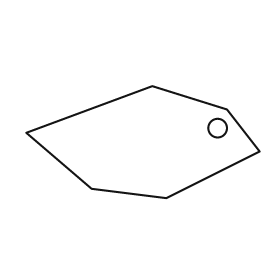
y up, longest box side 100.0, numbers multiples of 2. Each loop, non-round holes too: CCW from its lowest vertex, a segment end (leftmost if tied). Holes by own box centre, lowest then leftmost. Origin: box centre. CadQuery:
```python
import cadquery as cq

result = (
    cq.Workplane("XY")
    .moveTo(10.0, -24.0)
    .lineTo(50.0, -4.0)
    .lineTo(36.0, 14.0)
    .lineTo(4.0, 24.0)
    .lineTo(-50.0, 4.0)
    .lineTo(-22.0, -20.0)
    .close()
    .moveTo(32.0, 6.0)
    .circle(4.0)
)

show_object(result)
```